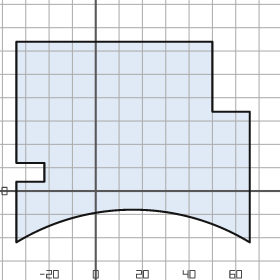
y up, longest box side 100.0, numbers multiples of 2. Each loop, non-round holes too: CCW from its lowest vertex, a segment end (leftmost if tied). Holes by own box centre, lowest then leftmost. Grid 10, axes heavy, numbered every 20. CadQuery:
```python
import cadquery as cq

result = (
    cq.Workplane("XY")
    .moveTo(-34.0, -22.0)
    .threePointArc((16.0, -8.0), (66.0, -22.0))
    .lineTo(66.0, 34.0)
    .lineTo(50.0, 34.0)
    .lineTo(50.0, 64.0)
    .lineTo(-34.0, 64.0)
    .lineTo(-34.0, 12.0)
    .lineTo(-22.0, 12.0)
    .lineTo(-22.0, 4.0)
    .lineTo(-34.0, 4.0)
    .close()
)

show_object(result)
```